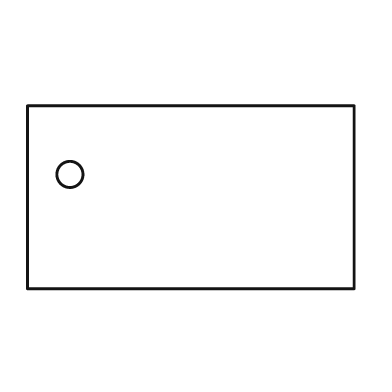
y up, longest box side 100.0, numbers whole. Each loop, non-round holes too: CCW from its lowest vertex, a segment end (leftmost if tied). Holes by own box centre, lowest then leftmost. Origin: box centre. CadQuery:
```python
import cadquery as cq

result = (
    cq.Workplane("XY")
    .moveTo(-50.0, -28.0)
    .lineTo(50.0, -28.0)
    .lineTo(50.0, 28.0)
    .lineTo(-50.0, 28.0)
    .close()
    .moveTo(-37.0, 7.0)
    .circle(4.0)
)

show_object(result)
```